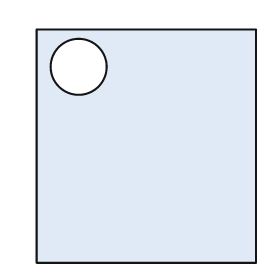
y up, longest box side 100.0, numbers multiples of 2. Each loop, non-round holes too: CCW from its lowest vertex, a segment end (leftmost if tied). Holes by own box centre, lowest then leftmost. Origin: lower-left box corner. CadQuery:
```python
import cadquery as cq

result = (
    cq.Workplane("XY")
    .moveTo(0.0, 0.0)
    .lineTo(94.0, 0.0)
    .lineTo(94.0, 100.0)
    .lineTo(0.0, 100.0)
    .close()
    .moveTo(18.0, 84.0)
    .circle(12.0)
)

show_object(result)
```